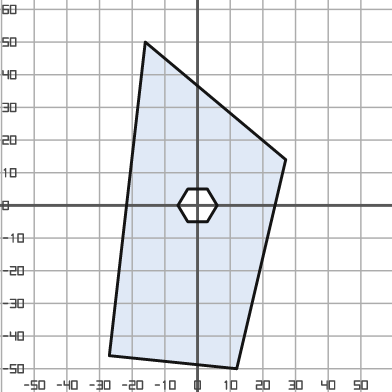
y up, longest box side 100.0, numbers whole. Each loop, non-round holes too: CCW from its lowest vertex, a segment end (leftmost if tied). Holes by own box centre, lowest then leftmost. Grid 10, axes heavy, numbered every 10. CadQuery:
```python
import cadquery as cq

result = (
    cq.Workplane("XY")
    .moveTo(12.0, -50.0)
    .lineTo(27.0, 14.0)
    .lineTo(-16.0, 50.0)
    .lineTo(-27.0, -46.0)
    .close()
    .moveTo(-3.0, -5.0)
    .lineTo(3.0, -5.0)
    .lineTo(6.0, 0.0)
    .lineTo(3.0, 5.0)
    .lineTo(-3.0, 5.0)
    .lineTo(-6.0, 0.0)
    .close()
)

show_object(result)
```